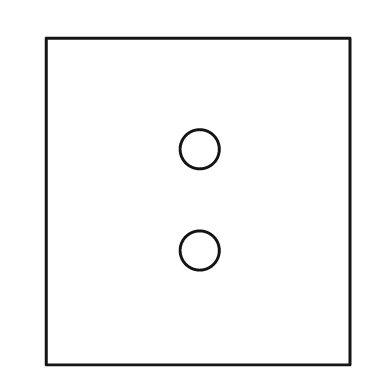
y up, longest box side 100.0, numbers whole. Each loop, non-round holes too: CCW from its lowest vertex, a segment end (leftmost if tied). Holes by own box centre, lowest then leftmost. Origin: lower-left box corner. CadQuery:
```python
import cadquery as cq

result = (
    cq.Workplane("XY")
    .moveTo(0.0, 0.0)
    .lineTo(93.0, 0.0)
    .lineTo(93.0, 100.0)
    .lineTo(0.0, 100.0)
    .close()
    .moveTo(47.0, 35.0)
    .circle(6.0)
    .moveTo(47.0, 66.0)
    .circle(6.0)
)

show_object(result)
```